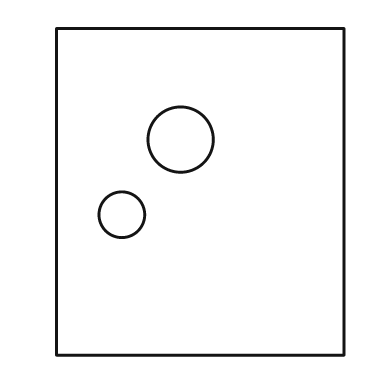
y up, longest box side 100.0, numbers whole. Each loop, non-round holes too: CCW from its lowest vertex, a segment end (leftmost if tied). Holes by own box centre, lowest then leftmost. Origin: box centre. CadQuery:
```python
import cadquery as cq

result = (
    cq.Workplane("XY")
    .moveTo(-44.0, -50.0)
    .lineTo(44.0, -50.0)
    .lineTo(44.0, 50.0)
    .lineTo(-44.0, 50.0)
    .close()
    .moveTo(-24.0, -7.0)
    .circle(7.0)
    .moveTo(-6.0, 16.0)
    .circle(10.0)
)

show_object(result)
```